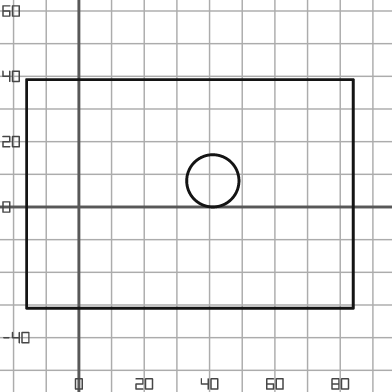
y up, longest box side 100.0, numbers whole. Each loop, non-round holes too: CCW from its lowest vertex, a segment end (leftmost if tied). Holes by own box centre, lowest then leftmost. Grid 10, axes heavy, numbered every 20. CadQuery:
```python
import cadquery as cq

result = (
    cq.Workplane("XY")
    .moveTo(-16.0, -31.0)
    .lineTo(84.0, -31.0)
    .lineTo(84.0, 39.0)
    .lineTo(-16.0, 39.0)
    .close()
    .moveTo(41.0, 8.0)
    .circle(8.0)
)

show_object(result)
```